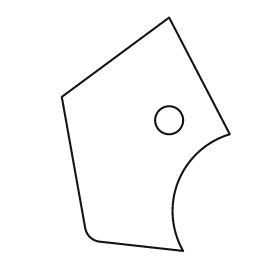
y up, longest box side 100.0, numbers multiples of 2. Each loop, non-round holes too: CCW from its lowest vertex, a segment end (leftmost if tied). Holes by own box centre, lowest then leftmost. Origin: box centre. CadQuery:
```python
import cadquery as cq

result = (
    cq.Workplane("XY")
    .moveTo(16.0, -50.0)
    .threePointArc((14.0, -20.0), (36.0, 0.0))
    .lineTo(10.0, 50.0)
    .lineTo(-36.0, 16.0)
    .lineTo(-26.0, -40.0)
    .threePointArc((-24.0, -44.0), (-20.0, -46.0))
    .close()
    .moveTo(10.0, 6.0)
    .circle(6.0)
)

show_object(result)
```